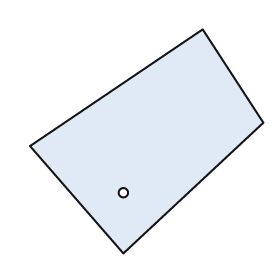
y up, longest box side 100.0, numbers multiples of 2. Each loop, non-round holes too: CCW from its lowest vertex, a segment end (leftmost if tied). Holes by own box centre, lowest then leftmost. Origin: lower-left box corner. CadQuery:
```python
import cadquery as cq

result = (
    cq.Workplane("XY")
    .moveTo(40.0, 0.0)
    .lineTo(100.0, 56.0)
    .lineTo(74.0, 96.0)
    .lineTo(0.0, 46.0)
    .close()
    .moveTo(40.0, 26.0)
    .circle(2.0)
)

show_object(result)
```